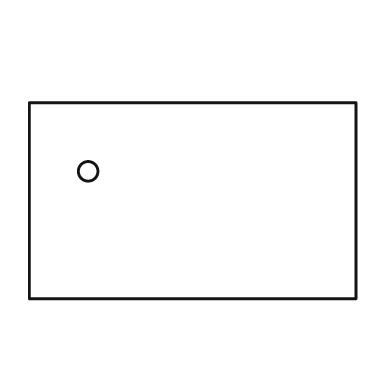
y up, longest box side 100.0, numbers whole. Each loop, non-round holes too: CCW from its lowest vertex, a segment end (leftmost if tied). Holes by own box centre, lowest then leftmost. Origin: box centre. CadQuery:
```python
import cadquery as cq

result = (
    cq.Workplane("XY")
    .moveTo(-50.0, -30.0)
    .lineTo(50.0, -30.0)
    .lineTo(50.0, 30.0)
    .lineTo(-50.0, 30.0)
    .close()
    .moveTo(-32.0, 9.0)
    .circle(3.0)
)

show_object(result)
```